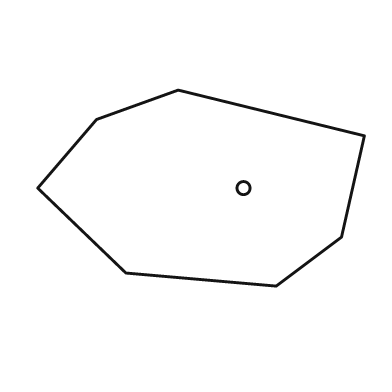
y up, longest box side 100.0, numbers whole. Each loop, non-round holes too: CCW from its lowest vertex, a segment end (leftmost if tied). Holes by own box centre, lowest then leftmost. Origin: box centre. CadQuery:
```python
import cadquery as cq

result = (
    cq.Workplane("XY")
    .moveTo(23.0, -30.0)
    .lineTo(43.0, -15.0)
    .lineTo(50.0, 16.0)
    .lineTo(-7.0, 30.0)
    .lineTo(-32.0, 21.0)
    .lineTo(-50.0, 0.0)
    .lineTo(-23.0, -26.0)
    .close()
    .moveTo(13.0, 0.0)
    .circle(2.0)
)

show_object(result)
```